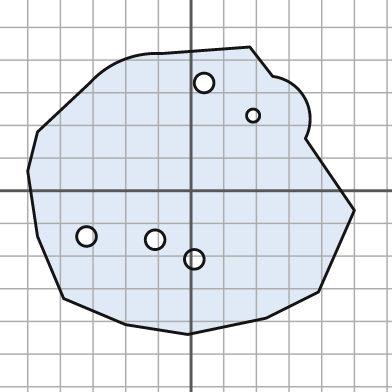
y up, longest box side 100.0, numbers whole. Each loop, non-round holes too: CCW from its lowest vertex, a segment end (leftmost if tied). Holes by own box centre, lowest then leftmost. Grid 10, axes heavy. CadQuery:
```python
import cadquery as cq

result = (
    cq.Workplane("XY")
    .moveTo(-1.0, -44.0)
    .lineTo(23.0, -39.0)
    .lineTo(39.0, -31.0)
    .lineTo(50.0, -6.0)
    .lineTo(35.0, 16.0)
    .threePointArc((35.0, 28.0), (25.0, 35.0))
    .lineTo(18.0, 44.0)
    .lineTo(-9.0, 42.0)
    .threePointArc((-21.0, 40.0), (-31.0, 33.0))
    .lineTo(-47.0, 18.0)
    .lineTo(-50.0, 6.0)
    .lineTo(-47.0, -14.0)
    .lineTo(-39.0, -33.0)
    .lineTo(-20.0, -41.0)
    .close()
    .moveTo(1.0, -21.0)
    .circle(3.0)
    .moveTo(-11.0, -15.0)
    .circle(3.0)
    .moveTo(-32.0, -14.0)
    .circle(3.0)
    .moveTo(19.0, 23.0)
    .circle(2.0)
    .moveTo(4.0, 33.0)
    .circle(3.0)
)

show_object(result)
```